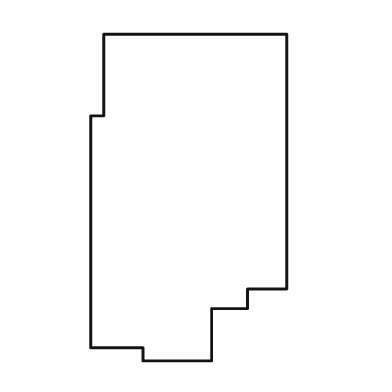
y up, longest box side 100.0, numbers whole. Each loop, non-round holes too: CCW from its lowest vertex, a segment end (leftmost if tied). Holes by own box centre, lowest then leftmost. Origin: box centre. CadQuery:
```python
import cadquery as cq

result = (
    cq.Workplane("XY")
    .moveTo(-14.0, -50.0)
    .lineTo(7.0, -50.0)
    .lineTo(7.0, -34.0)
    .lineTo(18.0, -34.0)
    .lineTo(18.0, -28.0)
    .lineTo(30.0, -28.0)
    .lineTo(30.0, 50.0)
    .lineTo(-26.0, 50.0)
    .lineTo(-26.0, 25.0)
    .lineTo(-30.0, 25.0)
    .lineTo(-30.0, -46.0)
    .lineTo(-14.0, -46.0)
    .close()
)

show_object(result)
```